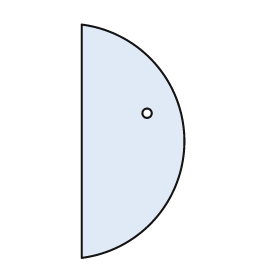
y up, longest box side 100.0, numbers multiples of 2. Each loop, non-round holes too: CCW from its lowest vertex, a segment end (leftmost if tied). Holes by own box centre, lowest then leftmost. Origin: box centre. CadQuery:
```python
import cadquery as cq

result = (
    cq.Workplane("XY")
    .moveTo(-22.0, -50.0)
    .threePointArc((22.0, 0.0), (-22.0, 50.0))
    .close()
    .moveTo(6.0, 12.0)
    .circle(2.0)
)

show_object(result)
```